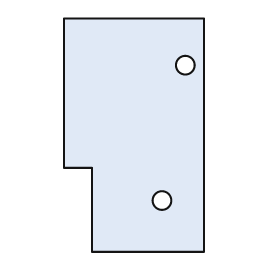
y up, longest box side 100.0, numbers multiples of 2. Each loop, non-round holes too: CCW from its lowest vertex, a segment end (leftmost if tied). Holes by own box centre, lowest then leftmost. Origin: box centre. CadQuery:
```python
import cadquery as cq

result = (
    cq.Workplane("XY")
    .moveTo(-18.0, -50.0)
    .lineTo(30.0, -50.0)
    .lineTo(30.0, 50.0)
    .lineTo(-30.0, 50.0)
    .lineTo(-30.0, -14.0)
    .lineTo(-18.0, -14.0)
    .close()
    .moveTo(12.0, -28.0)
    .circle(4.0)
    .moveTo(22.0, 30.0)
    .circle(4.0)
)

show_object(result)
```